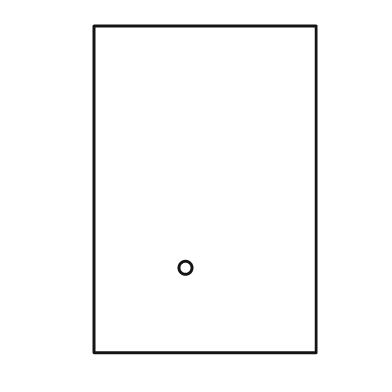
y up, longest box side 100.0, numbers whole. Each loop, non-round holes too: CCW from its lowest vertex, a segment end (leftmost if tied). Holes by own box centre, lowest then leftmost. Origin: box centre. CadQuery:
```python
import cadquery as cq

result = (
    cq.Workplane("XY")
    .moveTo(-34.0, -50.0)
    .lineTo(34.0, -50.0)
    .lineTo(34.0, 50.0)
    .lineTo(-34.0, 50.0)
    .close()
    .moveTo(-6.0, -24.0)
    .circle(2.0)
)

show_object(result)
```